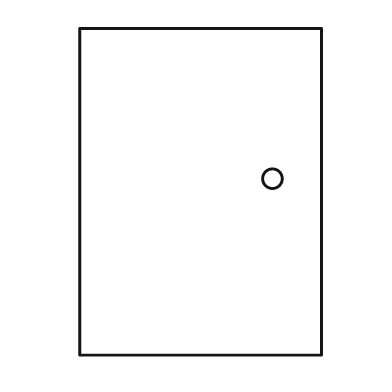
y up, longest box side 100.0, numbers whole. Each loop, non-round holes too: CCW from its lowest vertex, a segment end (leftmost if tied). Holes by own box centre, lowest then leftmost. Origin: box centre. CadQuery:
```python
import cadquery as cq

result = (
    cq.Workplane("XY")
    .moveTo(-37.0, -50.0)
    .lineTo(37.0, -50.0)
    .lineTo(37.0, 50.0)
    .lineTo(-37.0, 50.0)
    .close()
    .moveTo(22.0, 4.0)
    .circle(3.0)
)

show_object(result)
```